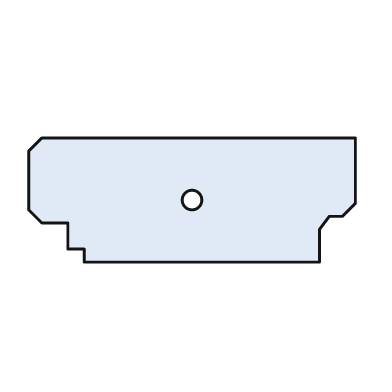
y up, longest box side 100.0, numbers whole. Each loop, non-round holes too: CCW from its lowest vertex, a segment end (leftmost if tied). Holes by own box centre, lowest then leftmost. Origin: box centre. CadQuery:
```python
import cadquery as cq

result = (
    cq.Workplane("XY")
    .moveTo(-33.0, -19.0)
    .lineTo(39.0, -19.0)
    .lineTo(39.0, -9.0)
    .lineTo(42.0, -5.0)
    .lineTo(46.0, -5.0)
    .lineTo(50.0, -1.0)
    .lineTo(50.0, 19.0)
    .lineTo(-46.0, 19.0)
    .lineTo(-50.0, 15.0)
    .lineTo(-50.0, -3.0)
    .lineTo(-46.0, -7.0)
    .lineTo(-38.0, -7.0)
    .lineTo(-38.0, -15.0)
    .lineTo(-33.0, -15.0)
    .close()
    .moveTo(0.0, 0.0)
    .circle(3.0)
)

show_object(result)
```